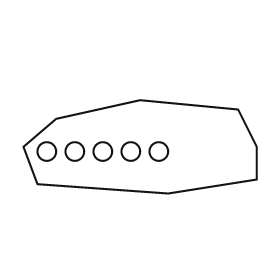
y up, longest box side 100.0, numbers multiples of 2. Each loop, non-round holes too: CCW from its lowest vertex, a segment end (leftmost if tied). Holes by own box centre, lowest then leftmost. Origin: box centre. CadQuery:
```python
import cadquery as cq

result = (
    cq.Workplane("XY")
    .moveTo(12.0, -20.0)
    .lineTo(50.0, -14.0)
    .lineTo(50.0, 0.0)
    .lineTo(42.0, 16.0)
    .lineTo(0.0, 20.0)
    .lineTo(-36.0, 12.0)
    .lineTo(-50.0, 0.0)
    .lineTo(-44.0, -16.0)
    .close()
    .moveTo(-40.0, -2.0)
    .circle(4.0)
    .moveTo(-28.0, -2.0)
    .circle(4.0)
    .moveTo(-16.0, -2.0)
    .circle(4.0)
    .moveTo(-4.0, -2.0)
    .circle(4.0)
    .moveTo(8.0, -2.0)
    .circle(4.0)
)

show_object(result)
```